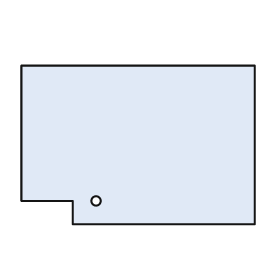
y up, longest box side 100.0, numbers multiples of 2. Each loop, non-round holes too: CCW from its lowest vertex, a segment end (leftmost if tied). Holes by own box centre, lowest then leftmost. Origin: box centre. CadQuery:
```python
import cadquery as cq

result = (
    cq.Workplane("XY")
    .moveTo(-28.0, -34.0)
    .lineTo(50.0, -34.0)
    .lineTo(50.0, 34.0)
    .lineTo(-50.0, 34.0)
    .lineTo(-50.0, -24.0)
    .lineTo(-28.0, -24.0)
    .close()
    .moveTo(-18.0, -24.0)
    .circle(2.0)
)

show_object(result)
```